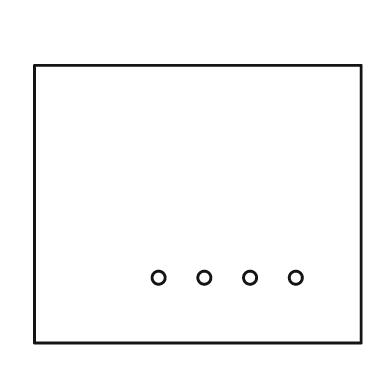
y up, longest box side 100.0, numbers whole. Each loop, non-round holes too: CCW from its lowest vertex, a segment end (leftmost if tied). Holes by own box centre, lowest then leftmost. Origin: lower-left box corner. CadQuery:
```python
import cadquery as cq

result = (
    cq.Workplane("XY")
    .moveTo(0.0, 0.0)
    .lineTo(100.0, 0.0)
    .lineTo(100.0, 85.0)
    .lineTo(0.0, 85.0)
    .close()
    .moveTo(38.0, 20.0)
    .circle(2.0)
    .moveTo(52.0, 20.0)
    .circle(2.0)
    .moveTo(66.0, 20.0)
    .circle(2.0)
    .moveTo(80.0, 20.0)
    .circle(2.0)
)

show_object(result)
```